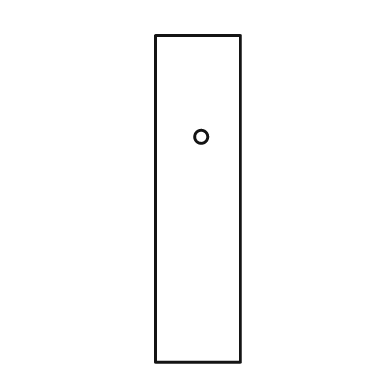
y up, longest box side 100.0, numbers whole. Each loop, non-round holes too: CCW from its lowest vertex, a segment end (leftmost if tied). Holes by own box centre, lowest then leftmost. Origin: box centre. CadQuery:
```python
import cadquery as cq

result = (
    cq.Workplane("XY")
    .moveTo(-13.0, -50.0)
    .lineTo(13.0, -50.0)
    .lineTo(13.0, 50.0)
    .lineTo(-13.0, 50.0)
    .close()
    .moveTo(1.0, 19.0)
    .circle(2.0)
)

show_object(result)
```